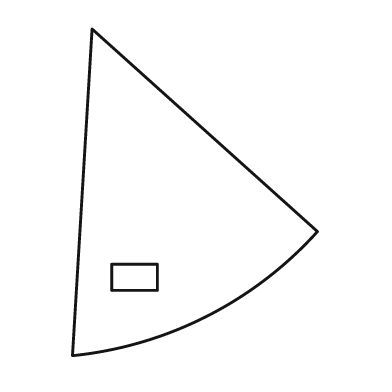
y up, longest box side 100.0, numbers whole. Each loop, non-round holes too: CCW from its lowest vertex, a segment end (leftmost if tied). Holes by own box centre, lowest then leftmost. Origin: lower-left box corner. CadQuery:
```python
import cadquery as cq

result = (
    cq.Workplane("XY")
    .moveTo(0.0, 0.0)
    .threePointArc((41.0, 12.0), (75.0, 38.0))
    .lineTo(6.0, 100.0)
    .close()
    .moveTo(12.0, 20.0)
    .lineTo(26.0, 20.0)
    .lineTo(26.0, 28.0)
    .lineTo(12.0, 28.0)
    .close()
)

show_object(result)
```